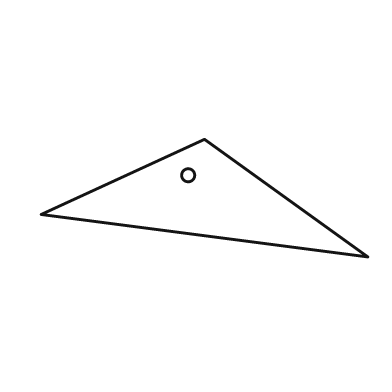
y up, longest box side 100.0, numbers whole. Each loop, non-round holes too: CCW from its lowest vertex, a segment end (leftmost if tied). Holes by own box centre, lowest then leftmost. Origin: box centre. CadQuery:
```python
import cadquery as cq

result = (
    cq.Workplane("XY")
    .moveTo(50.0, -18.0)
    .lineTo(0.0, 18.0)
    .lineTo(-50.0, -5.0)
    .close()
    .moveTo(-5.0, 7.0)
    .circle(2.0)
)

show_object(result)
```